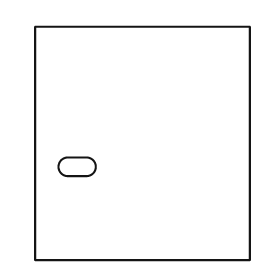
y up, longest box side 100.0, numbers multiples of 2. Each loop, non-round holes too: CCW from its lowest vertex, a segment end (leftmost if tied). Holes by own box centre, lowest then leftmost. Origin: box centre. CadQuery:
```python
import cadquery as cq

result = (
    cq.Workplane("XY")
    .moveTo(-46.0, -50.0)
    .lineTo(46.0, -50.0)
    .lineTo(46.0, 50.0)
    .lineTo(-46.0, 50.0)
    .close()
    .moveTo(-32.0, -14.0)
    .lineTo(-24.0, -14.0)
    .threePointArc((-20.0, -10.0), (-24.0, -6.0))
    .lineTo(-32.0, -6.0)
    .threePointArc((-36.0, -10.0), (-32.0, -14.0))
    .close()
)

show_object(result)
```